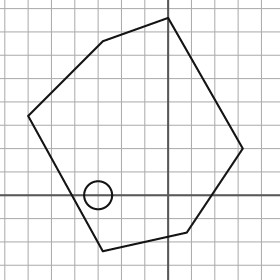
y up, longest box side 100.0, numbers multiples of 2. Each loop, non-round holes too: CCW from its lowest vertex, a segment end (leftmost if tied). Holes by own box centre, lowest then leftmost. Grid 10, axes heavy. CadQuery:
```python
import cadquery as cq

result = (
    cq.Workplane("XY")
    .moveTo(-28.0, -24.0)
    .lineTo(8.0, -16.0)
    .lineTo(32.0, 20.0)
    .lineTo(0.0, 76.0)
    .lineTo(-28.0, 66.0)
    .lineTo(-60.0, 34.0)
    .close()
    .moveTo(-30.0, 0.0)
    .circle(6.0)
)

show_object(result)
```